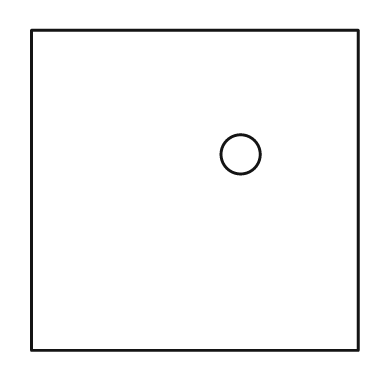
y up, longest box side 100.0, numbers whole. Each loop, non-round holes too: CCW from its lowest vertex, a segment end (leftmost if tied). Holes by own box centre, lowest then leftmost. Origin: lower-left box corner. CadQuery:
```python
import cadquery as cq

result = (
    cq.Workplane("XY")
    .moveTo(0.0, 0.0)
    .lineTo(100.0, 0.0)
    .lineTo(100.0, 98.0)
    .lineTo(0.0, 98.0)
    .close()
    .moveTo(64.0, 60.0)
    .circle(6.0)
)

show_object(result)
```